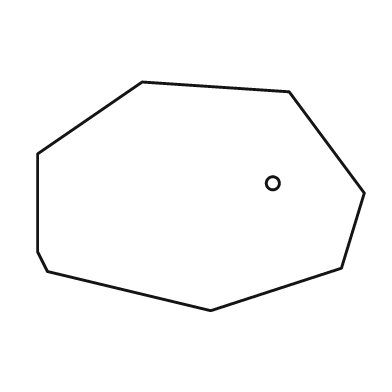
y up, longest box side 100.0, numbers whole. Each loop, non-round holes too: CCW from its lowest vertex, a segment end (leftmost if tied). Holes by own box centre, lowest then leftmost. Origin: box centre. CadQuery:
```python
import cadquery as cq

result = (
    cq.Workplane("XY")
    .moveTo(3.0, -35.0)
    .lineTo(43.0, -22.0)
    .lineTo(50.0, 1.0)
    .lineTo(27.0, 32.0)
    .lineTo(-18.0, 35.0)
    .lineTo(-50.0, 13.0)
    .lineTo(-50.0, -17.0)
    .lineTo(-47.0, -23.0)
    .close()
    .moveTo(22.0, 4.0)
    .circle(2.0)
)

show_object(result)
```